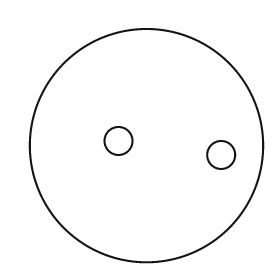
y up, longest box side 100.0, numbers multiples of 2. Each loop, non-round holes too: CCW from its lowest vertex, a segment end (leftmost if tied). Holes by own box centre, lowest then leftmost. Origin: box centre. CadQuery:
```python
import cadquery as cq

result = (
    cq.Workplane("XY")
    .moveTo(0.0, 0.0)
    .circle(50.0)
    .moveTo(32.0, -4.0)
    .circle(6.0)
    .moveTo(-12.0, 2.0)
    .circle(6.0)
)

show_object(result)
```